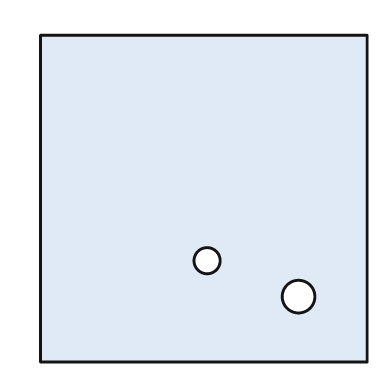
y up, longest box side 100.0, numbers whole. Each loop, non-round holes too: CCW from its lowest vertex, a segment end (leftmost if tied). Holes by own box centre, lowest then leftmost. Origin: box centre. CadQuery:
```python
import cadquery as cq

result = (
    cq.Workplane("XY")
    .moveTo(-50.0, -50.0)
    .lineTo(50.0, -50.0)
    .lineTo(50.0, 50.0)
    .lineTo(-50.0, 50.0)
    .close()
    .moveTo(29.0, -30.0)
    .circle(5.0)
    .moveTo(1.0, -19.0)
    .circle(4.0)
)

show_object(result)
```